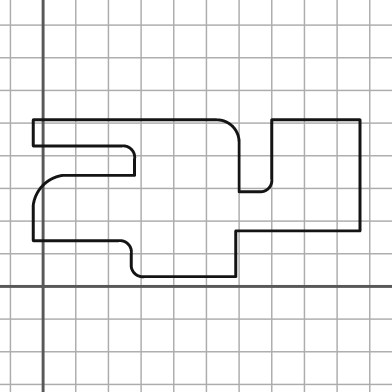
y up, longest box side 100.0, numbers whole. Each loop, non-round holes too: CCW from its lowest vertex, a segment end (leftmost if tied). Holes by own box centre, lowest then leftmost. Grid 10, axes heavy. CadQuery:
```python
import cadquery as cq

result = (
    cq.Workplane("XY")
    .moveTo(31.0, 3.0)
    .lineTo(59.0, 3.0)
    .lineTo(59.0, 17.0)
    .lineTo(97.0, 17.0)
    .lineTo(97.0, 51.0)
    .lineTo(70.0, 51.0)
    .lineTo(70.0, 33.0)
    .threePointArc((69.0, 30.0), (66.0, 29.0))
    .lineTo(60.0, 29.0)
    .lineTo(60.0, 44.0)
    .threePointArc((58.0, 49.0), (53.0, 51.0))
    .lineTo(-3.0, 51.0)
    .lineTo(-3.0, 43.0)
    .lineTo(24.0, 43.0)
    .threePointArc((27.0, 42.0), (28.0, 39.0))
    .lineTo(28.0, 34.0)
    .lineTo(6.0, 34.0)
    .threePointArc((0.0, 31.0), (-3.0, 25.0))
    .lineTo(-3.0, 14.0)
    .lineTo(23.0, 14.0)
    .threePointArc((26.0, 13.0), (27.0, 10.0))
    .lineTo(27.0, 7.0)
    .threePointArc((28.0, 4.0), (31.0, 3.0))
    .close()
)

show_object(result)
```